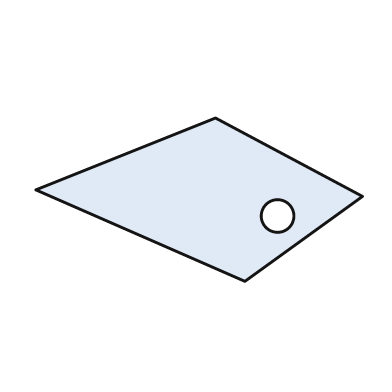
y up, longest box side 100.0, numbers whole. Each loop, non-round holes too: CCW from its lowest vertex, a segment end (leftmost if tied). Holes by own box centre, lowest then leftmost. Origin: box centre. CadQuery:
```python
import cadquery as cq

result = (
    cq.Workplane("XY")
    .moveTo(14.0, -25.0)
    .lineTo(50.0, 1.0)
    .lineTo(5.0, 25.0)
    .lineTo(-50.0, 3.0)
    .close()
    .moveTo(24.0, -5.0)
    .circle(5.0)
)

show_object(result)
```